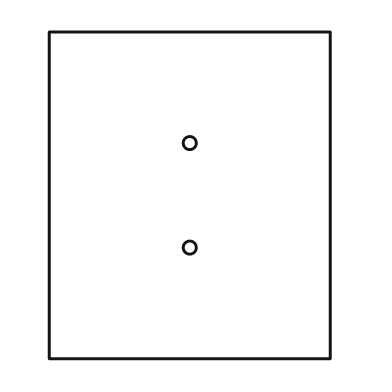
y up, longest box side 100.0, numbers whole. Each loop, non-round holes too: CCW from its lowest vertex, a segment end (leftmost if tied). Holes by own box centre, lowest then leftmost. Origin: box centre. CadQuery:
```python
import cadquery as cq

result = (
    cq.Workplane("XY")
    .moveTo(-43.0, -50.0)
    .lineTo(43.0, -50.0)
    .lineTo(43.0, 50.0)
    .lineTo(-43.0, 50.0)
    .close()
    .moveTo(0.0, -16.0)
    .circle(2.0)
    .moveTo(0.0, 16.0)
    .circle(2.0)
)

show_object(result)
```